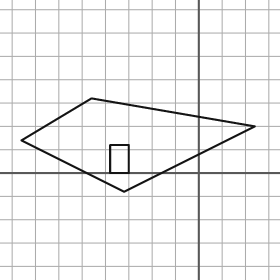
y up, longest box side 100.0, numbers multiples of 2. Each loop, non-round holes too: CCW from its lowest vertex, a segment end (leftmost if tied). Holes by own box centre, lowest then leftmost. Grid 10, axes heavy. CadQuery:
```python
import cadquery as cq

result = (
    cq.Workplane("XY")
    .moveTo(-32.0, -8.0)
    .lineTo(24.0, 20.0)
    .lineTo(-46.0, 32.0)
    .lineTo(-76.0, 14.0)
    .close()
    .moveTo(-38.0, 0.0)
    .lineTo(-30.0, 0.0)
    .lineTo(-30.0, 12.0)
    .lineTo(-38.0, 12.0)
    .close()
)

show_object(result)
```